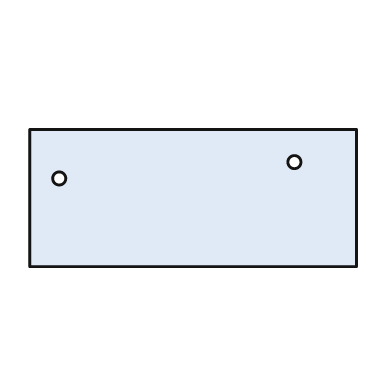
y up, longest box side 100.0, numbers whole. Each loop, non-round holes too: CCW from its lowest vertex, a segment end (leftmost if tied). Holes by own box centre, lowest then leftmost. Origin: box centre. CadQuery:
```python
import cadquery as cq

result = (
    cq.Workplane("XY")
    .moveTo(-50.0, -21.0)
    .lineTo(50.0, -21.0)
    .lineTo(50.0, 21.0)
    .lineTo(-50.0, 21.0)
    .close()
    .moveTo(-41.0, 6.0)
    .circle(2.0)
    .moveTo(31.0, 11.0)
    .circle(2.0)
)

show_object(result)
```